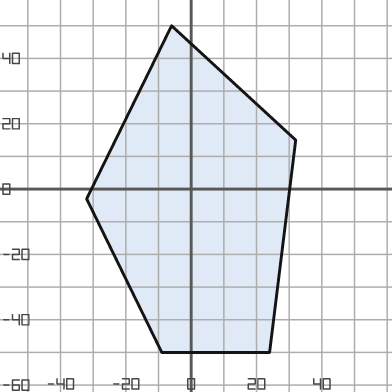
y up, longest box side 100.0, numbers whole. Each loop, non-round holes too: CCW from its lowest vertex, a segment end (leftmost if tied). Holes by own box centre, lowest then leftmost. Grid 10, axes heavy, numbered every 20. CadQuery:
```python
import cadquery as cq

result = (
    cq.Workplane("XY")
    .moveTo(-9.0, -50.0)
    .lineTo(24.0, -50.0)
    .lineTo(32.0, 15.0)
    .lineTo(-6.0, 50.0)
    .lineTo(-32.0, -3.0)
    .close()
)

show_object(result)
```